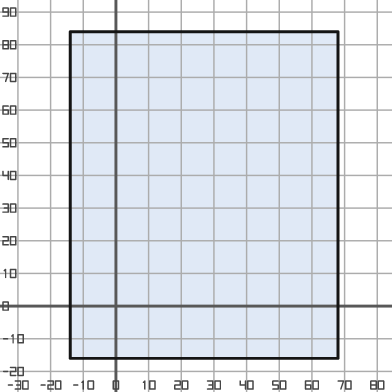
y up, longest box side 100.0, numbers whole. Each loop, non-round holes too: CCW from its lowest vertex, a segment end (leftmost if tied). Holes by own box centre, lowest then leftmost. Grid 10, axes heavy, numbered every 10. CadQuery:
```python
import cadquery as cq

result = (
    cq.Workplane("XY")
    .moveTo(-14.0, -16.0)
    .lineTo(68.0, -16.0)
    .lineTo(68.0, 84.0)
    .lineTo(-14.0, 84.0)
    .close()
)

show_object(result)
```